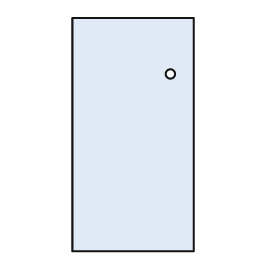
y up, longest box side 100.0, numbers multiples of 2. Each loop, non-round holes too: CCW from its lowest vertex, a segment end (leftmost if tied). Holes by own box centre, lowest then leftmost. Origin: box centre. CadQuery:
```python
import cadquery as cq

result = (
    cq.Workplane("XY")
    .moveTo(-26.0, -50.0)
    .lineTo(26.0, -50.0)
    .lineTo(26.0, 50.0)
    .lineTo(-26.0, 50.0)
    .close()
    .moveTo(16.0, 26.0)
    .circle(2.0)
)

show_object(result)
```